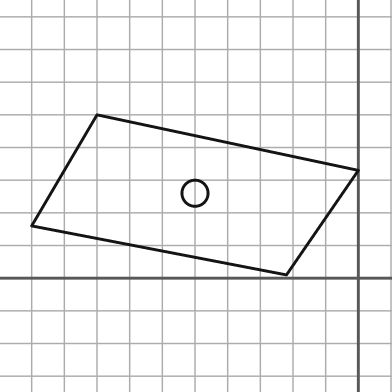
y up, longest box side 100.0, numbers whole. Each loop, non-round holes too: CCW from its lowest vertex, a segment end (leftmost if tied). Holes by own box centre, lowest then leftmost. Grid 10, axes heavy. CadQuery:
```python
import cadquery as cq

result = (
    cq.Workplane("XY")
    .moveTo(-22.0, 1.0)
    .lineTo(0.0, 33.0)
    .lineTo(-80.0, 50.0)
    .lineTo(-100.0, 16.0)
    .close()
    .moveTo(-50.0, 26.0)
    .circle(4.0)
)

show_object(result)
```